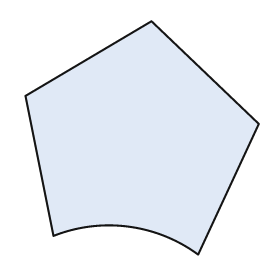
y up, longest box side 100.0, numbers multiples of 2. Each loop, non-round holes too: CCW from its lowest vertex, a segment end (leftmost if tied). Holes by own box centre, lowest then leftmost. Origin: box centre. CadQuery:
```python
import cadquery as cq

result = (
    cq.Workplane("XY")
    .moveTo(24.0, -50.0)
    .lineTo(50.0, 6.0)
    .lineTo(4.0, 50.0)
    .lineTo(-50.0, 18.0)
    .lineTo(-38.0, -42.0)
    .threePointArc((-6.0, -38.0), (24.0, -50.0))
    .close()
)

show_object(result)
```